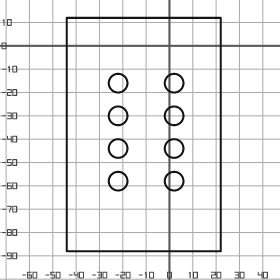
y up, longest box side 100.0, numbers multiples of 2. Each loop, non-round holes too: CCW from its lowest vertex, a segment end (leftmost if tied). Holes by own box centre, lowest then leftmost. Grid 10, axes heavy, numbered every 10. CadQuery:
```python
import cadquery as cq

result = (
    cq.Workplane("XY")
    .moveTo(-44.0, -88.0)
    .lineTo(22.0, -88.0)
    .lineTo(22.0, 12.0)
    .lineTo(-44.0, 12.0)
    .close()
    .moveTo(-22.0, -58.0)
    .circle(4.0)
    .moveTo(2.0, -58.0)
    .circle(4.0)
    .moveTo(-22.0, -44.0)
    .circle(4.0)
    .moveTo(2.0, -44.0)
    .circle(4.0)
    .moveTo(-22.0, -30.0)
    .circle(4.0)
    .moveTo(2.0, -30.0)
    .circle(4.0)
    .moveTo(-22.0, -16.0)
    .circle(4.0)
    .moveTo(2.0, -16.0)
    .circle(4.0)
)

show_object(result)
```